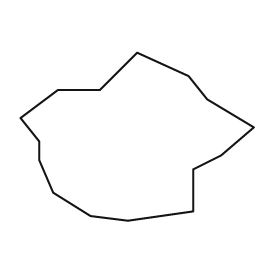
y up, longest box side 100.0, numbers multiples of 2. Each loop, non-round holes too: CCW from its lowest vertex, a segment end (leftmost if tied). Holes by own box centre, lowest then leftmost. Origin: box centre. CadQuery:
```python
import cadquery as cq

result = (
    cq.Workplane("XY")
    .moveTo(-4.0, -36.0)
    .lineTo(24.0, -32.0)
    .lineTo(24.0, -14.0)
    .lineTo(36.0, -8.0)
    .lineTo(50.0, 4.0)
    .lineTo(30.0, 16.0)
    .lineTo(22.0, 26.0)
    .lineTo(0.0, 36.0)
    .lineTo(-16.0, 20.0)
    .lineTo(-34.0, 20.0)
    .lineTo(-50.0, 8.0)
    .lineTo(-42.0, -2.0)
    .lineTo(-42.0, -10.0)
    .lineTo(-36.0, -24.0)
    .lineTo(-20.0, -34.0)
    .close()
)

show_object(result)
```